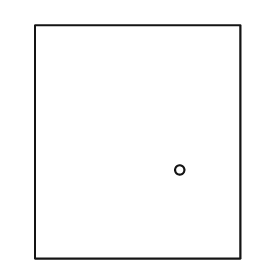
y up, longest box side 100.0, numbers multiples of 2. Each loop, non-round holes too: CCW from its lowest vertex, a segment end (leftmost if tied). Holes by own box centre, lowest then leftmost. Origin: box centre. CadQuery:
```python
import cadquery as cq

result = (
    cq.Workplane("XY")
    .moveTo(-44.0, -50.0)
    .lineTo(44.0, -50.0)
    .lineTo(44.0, 50.0)
    .lineTo(-44.0, 50.0)
    .close()
    .moveTo(18.0, -12.0)
    .circle(2.0)
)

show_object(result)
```